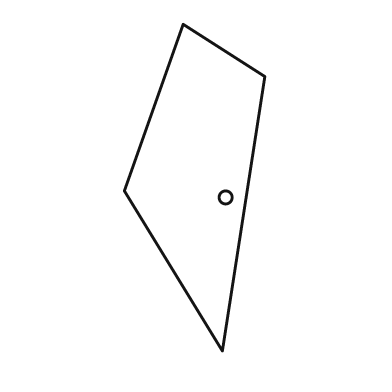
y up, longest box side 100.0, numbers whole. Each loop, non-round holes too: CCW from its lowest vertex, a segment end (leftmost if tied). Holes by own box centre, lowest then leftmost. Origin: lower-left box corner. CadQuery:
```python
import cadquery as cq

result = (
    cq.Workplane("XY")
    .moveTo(30.0, 0.0)
    .lineTo(43.0, 84.0)
    .lineTo(18.0, 100.0)
    .lineTo(0.0, 49.0)
    .close()
    .moveTo(31.0, 47.0)
    .circle(2.0)
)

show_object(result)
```